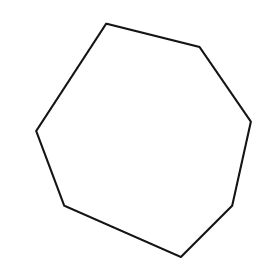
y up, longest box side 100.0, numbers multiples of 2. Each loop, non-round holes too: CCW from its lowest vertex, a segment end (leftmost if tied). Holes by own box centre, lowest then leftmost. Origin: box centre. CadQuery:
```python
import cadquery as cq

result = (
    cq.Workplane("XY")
    .moveTo(16.0, -50.0)
    .lineTo(38.0, -28.0)
    .lineTo(46.0, 8.0)
    .lineTo(24.0, 40.0)
    .lineTo(-16.0, 50.0)
    .lineTo(-46.0, 4.0)
    .lineTo(-34.0, -28.0)
    .close()
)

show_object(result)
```